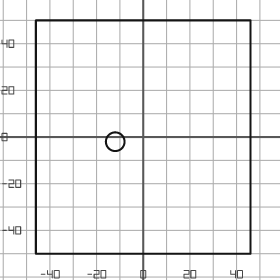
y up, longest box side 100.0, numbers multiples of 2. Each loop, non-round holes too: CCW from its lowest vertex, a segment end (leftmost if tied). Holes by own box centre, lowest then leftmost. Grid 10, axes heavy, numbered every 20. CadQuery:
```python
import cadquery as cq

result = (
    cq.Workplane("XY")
    .moveTo(-46.0, -50.0)
    .lineTo(46.0, -50.0)
    .lineTo(46.0, 50.0)
    .lineTo(-46.0, 50.0)
    .close()
    .moveTo(-12.0, -2.0)
    .circle(4.0)
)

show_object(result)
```